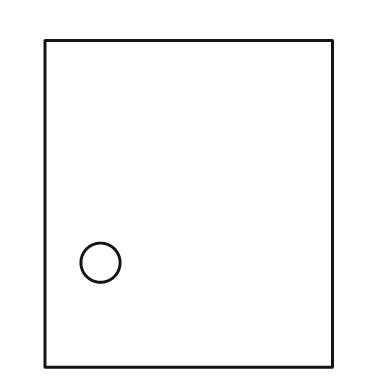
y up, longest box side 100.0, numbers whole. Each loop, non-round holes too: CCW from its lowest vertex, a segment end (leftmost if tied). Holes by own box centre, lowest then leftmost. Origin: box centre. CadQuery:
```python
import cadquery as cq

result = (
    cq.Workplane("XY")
    .moveTo(-44.0, -50.0)
    .lineTo(44.0, -50.0)
    .lineTo(44.0, 50.0)
    .lineTo(-44.0, 50.0)
    .close()
    .moveTo(-27.0, -18.0)
    .circle(6.0)
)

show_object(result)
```